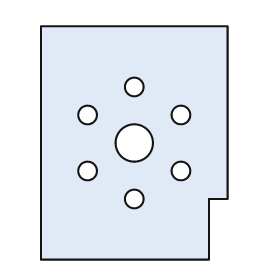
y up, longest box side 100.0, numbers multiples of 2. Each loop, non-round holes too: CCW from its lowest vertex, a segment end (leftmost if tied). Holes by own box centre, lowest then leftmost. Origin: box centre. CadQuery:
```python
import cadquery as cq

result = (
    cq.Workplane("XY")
    .moveTo(-40.0, -50.0)
    .lineTo(32.0, -50.0)
    .lineTo(32.0, -24.0)
    .lineTo(40.0, -24.0)
    .lineTo(40.0, 50.0)
    .lineTo(-40.0, 50.0)
    .close()
    .moveTo(0.0, -24.0)
    .circle(4.0)
    .moveTo(-20.0, -12.0)
    .circle(4.0)
    .moveTo(20.0, -12.0)
    .circle(4.0)
    .moveTo(0.0, 0.0)
    .circle(8.0)
    .moveTo(-20.0, 12.0)
    .circle(4.0)
    .moveTo(20.0, 12.0)
    .circle(4.0)
    .moveTo(0.0, 24.0)
    .circle(4.0)
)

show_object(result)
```